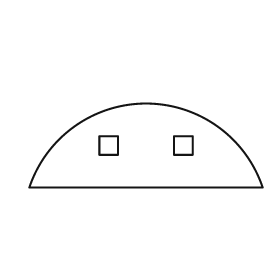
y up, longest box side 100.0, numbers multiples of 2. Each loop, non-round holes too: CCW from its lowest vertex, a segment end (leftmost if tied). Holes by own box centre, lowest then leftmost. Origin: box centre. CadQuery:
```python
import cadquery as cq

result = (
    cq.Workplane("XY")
    .moveTo(-50.0, -18.0)
    .lineTo(50.0, -18.0)
    .threePointArc((0.0, 18.0), (-50.0, -18.0))
    .close()
    .moveTo(-20.0, -4.0)
    .lineTo(-12.0, -4.0)
    .lineTo(-12.0, 4.0)
    .lineTo(-20.0, 4.0)
    .close()
    .moveTo(12.0, -4.0)
    .lineTo(20.0, -4.0)
    .lineTo(20.0, 4.0)
    .lineTo(12.0, 4.0)
    .close()
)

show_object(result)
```